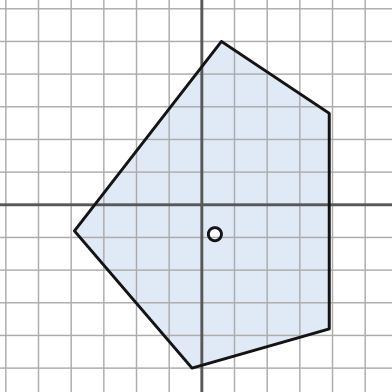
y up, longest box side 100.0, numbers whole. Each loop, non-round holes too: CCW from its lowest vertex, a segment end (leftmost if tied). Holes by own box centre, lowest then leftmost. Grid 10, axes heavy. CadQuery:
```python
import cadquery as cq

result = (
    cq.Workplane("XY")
    .moveTo(-3.0, -50.0)
    .lineTo(39.0, -38.0)
    .lineTo(39.0, 28.0)
    .lineTo(6.0, 50.0)
    .lineTo(-39.0, -8.0)
    .close()
    .moveTo(4.0, -9.0)
    .circle(2.0)
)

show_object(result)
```